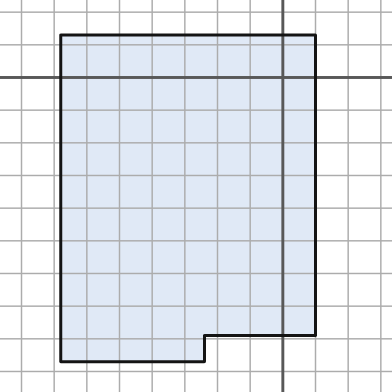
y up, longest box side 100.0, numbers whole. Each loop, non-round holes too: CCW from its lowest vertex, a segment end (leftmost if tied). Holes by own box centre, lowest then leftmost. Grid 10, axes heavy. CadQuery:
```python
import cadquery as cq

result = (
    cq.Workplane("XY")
    .moveTo(-68.0, -87.0)
    .lineTo(-24.0, -87.0)
    .lineTo(-24.0, -79.0)
    .lineTo(10.0, -79.0)
    .lineTo(10.0, 13.0)
    .lineTo(-68.0, 13.0)
    .close()
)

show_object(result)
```